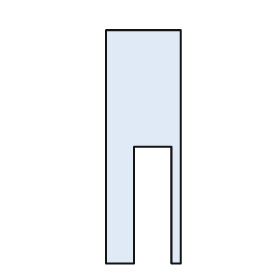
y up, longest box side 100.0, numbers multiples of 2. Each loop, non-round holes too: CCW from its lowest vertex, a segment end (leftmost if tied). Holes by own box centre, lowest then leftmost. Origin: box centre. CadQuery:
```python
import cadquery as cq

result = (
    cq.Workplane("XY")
    .moveTo(-16.0, -50.0)
    .lineTo(-4.0, -50.0)
    .lineTo(-4.0, 0.0)
    .lineTo(12.0, 0.0)
    .lineTo(12.0, -50.0)
    .lineTo(16.0, -50.0)
    .lineTo(16.0, 50.0)
    .lineTo(-16.0, 50.0)
    .close()
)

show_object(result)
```